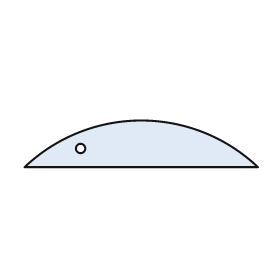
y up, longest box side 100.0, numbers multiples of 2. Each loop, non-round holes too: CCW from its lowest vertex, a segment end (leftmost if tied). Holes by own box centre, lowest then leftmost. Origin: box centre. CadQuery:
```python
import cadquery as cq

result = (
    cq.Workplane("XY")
    .moveTo(-50.0, -10.0)
    .lineTo(50.0, -10.0)
    .threePointArc((0.0, 10.0), (-50.0, -10.0))
    .close()
    .moveTo(-26.0, -2.0)
    .circle(2.0)
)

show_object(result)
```